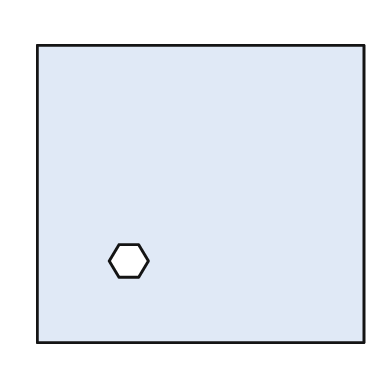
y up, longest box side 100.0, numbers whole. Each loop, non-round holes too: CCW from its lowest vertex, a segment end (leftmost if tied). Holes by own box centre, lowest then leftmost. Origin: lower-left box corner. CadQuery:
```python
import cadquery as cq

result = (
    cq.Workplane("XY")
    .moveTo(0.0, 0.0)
    .lineTo(100.0, 0.0)
    .lineTo(100.0, 91.0)
    .lineTo(0.0, 91.0)
    .close()
    .moveTo(25.0, 20.0)
    .lineTo(31.0, 20.0)
    .lineTo(34.0, 25.0)
    .lineTo(31.0, 30.0)
    .lineTo(25.0, 30.0)
    .lineTo(22.0, 25.0)
    .close()
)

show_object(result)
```